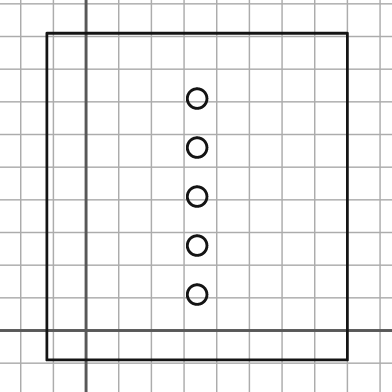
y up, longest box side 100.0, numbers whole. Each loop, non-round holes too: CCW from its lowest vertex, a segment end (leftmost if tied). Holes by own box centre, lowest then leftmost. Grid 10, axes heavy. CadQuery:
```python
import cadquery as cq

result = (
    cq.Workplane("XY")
    .moveTo(-12.0, -9.0)
    .lineTo(80.0, -9.0)
    .lineTo(80.0, 91.0)
    .lineTo(-12.0, 91.0)
    .close()
    .moveTo(34.0, 11.0)
    .circle(3.0)
    .moveTo(34.0, 26.0)
    .circle(3.0)
    .moveTo(34.0, 41.0)
    .circle(3.0)
    .moveTo(34.0, 56.0)
    .circle(3.0)
    .moveTo(34.0, 71.0)
    .circle(3.0)
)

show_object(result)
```